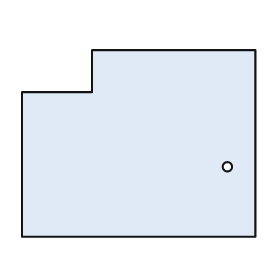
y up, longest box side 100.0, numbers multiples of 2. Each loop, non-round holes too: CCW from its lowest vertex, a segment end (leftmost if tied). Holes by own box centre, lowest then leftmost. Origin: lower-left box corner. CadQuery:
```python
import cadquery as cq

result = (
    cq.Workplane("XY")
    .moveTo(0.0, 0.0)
    .lineTo(100.0, 0.0)
    .lineTo(100.0, 80.0)
    .lineTo(30.0, 80.0)
    .lineTo(30.0, 62.0)
    .lineTo(0.0, 62.0)
    .close()
    .moveTo(88.0, 30.0)
    .circle(2.0)
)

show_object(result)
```